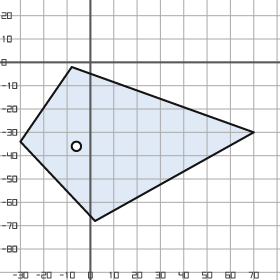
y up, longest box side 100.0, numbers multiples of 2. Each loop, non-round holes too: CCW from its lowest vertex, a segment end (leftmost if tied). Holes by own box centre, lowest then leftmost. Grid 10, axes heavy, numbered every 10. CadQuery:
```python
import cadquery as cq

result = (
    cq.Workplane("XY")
    .moveTo(2.0, -68.0)
    .lineTo(70.0, -30.0)
    .lineTo(-8.0, -2.0)
    .lineTo(-30.0, -34.0)
    .close()
    .moveTo(-6.0, -36.0)
    .circle(2.0)
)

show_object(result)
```